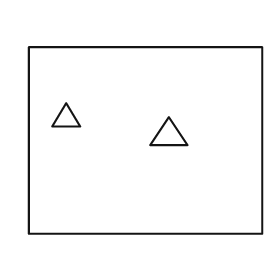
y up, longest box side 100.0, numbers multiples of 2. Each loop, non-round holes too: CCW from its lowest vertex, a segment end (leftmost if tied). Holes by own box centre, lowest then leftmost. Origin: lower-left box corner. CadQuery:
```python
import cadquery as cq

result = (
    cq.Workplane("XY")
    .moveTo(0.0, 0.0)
    .lineTo(100.0, 0.0)
    .lineTo(100.0, 80.0)
    .lineTo(0.0, 80.0)
    .close()
    .moveTo(52.0, 38.0)
    .lineTo(68.0, 38.0)
    .lineTo(60.0, 50.0)
    .close()
    .moveTo(10.0, 46.0)
    .lineTo(22.0, 46.0)
    .lineTo(16.0, 56.0)
    .close()
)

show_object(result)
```